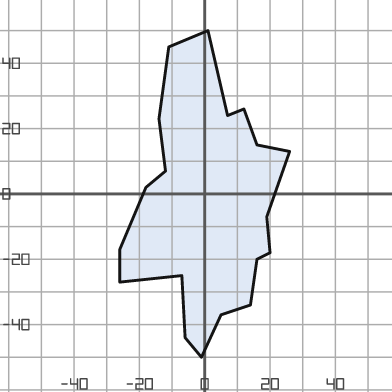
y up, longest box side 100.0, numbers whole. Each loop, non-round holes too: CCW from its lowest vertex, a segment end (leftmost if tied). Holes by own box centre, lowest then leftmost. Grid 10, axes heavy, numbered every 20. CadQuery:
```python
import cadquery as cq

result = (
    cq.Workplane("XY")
    .moveTo(-1.0, -50.0)
    .lineTo(5.0, -37.0)
    .lineTo(14.0, -34.0)
    .lineTo(16.0, -20.0)
    .lineTo(20.0, -18.0)
    .lineTo(19.0, -7.0)
    .lineTo(26.0, 13.0)
    .lineTo(16.0, 15.0)
    .lineTo(12.0, 26.0)
    .lineTo(7.0, 24.0)
    .lineTo(1.0, 50.0)
    .lineTo(-11.0, 45.0)
    .lineTo(-14.0, 23.0)
    .lineTo(-12.0, 7.0)
    .lineTo(-18.0, 2.0)
    .lineTo(-26.0, -17.0)
    .lineTo(-26.0, -27.0)
    .lineTo(-7.0, -25.0)
    .lineTo(-6.0, -44.0)
    .close()
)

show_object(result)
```